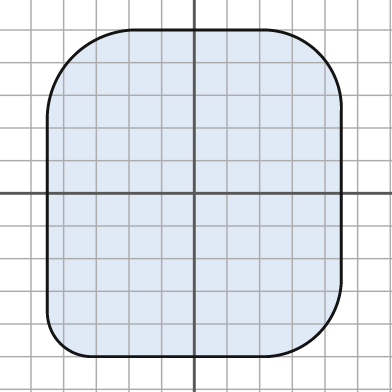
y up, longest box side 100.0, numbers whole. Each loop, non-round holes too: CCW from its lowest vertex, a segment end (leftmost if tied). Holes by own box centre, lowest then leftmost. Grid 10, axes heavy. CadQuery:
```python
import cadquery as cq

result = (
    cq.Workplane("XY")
    .moveTo(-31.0, -50.0)
    .lineTo(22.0, -50.0)
    .threePointArc((38.0, -43.0), (45.0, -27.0))
    .lineTo(45.0, 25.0)
    .threePointArc((38.0, 43.0), (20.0, 50.0))
    .lineTo(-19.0, 50.0)
    .threePointArc((-37.0, 42.0), (-45.0, 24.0))
    .lineTo(-45.0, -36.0)
    .threePointArc((-41.0, -46.0), (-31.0, -50.0))
    .close()
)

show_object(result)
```